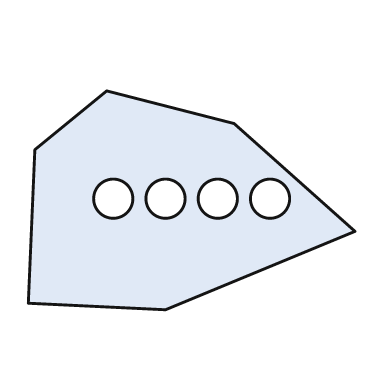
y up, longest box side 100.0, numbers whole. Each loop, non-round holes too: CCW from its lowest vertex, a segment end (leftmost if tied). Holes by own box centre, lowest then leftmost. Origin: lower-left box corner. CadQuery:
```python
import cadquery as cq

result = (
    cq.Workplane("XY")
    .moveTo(42.0, 0.0)
    .lineTo(100.0, 24.0)
    .lineTo(63.0, 57.0)
    .lineTo(24.0, 67.0)
    .lineTo(2.0, 49.0)
    .lineTo(0.0, 2.0)
    .close()
    .moveTo(26.0, 34.0)
    .circle(6.0)
    .moveTo(42.0, 34.0)
    .circle(6.0)
    .moveTo(58.0, 34.0)
    .circle(6.0)
    .moveTo(74.0, 34.0)
    .circle(6.0)
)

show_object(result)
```